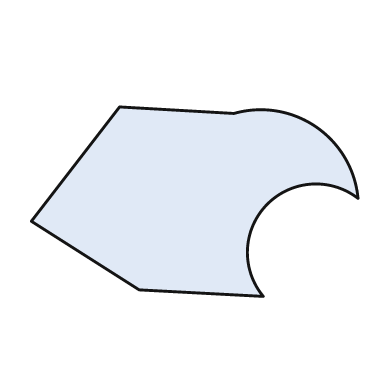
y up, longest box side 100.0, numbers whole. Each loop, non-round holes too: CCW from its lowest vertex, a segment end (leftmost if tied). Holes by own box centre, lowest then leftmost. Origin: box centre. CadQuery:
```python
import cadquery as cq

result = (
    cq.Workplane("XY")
    .moveTo(21.0, -29.0)
    .threePointArc((22.0, -1.0), (50.0, 1.0))
    .threePointArc((37.0, 23.0), (12.0, 27.0))
    .lineTo(-23.0, 29.0)
    .lineTo(-50.0, -6.0)
    .lineTo(-17.0, -27.0)
    .close()
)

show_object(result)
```